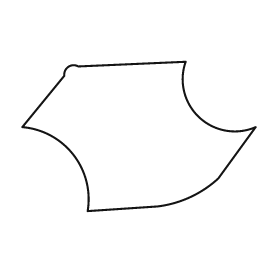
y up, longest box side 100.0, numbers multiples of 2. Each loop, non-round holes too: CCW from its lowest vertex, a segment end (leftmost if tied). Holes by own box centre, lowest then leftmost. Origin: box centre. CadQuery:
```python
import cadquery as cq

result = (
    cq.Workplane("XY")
    .moveTo(-22.0, -32.0)
    .lineTo(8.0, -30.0)
    .threePointArc((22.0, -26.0), (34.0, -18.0))
    .lineTo(50.0, 4.0)
    .threePointArc((26.0, 8.0), (20.0, 32.0))
    .lineTo(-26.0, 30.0)
    .threePointArc((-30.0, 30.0), (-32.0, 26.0))
    .lineTo(-50.0, 4.0)
    .threePointArc((-28.0, -8.0), (-22.0, -32.0))
    .close()
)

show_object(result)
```